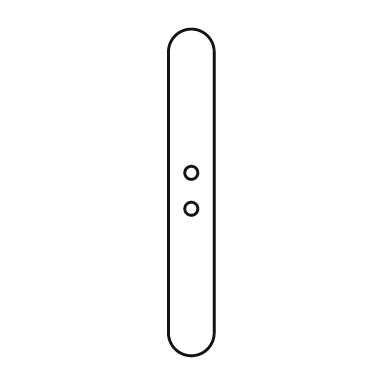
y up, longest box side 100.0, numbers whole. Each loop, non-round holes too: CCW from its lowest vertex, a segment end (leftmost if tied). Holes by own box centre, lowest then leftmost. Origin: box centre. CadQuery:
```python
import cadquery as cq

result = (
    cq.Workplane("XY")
    .moveTo(-7.0, -43.0)
    .threePointArc((0.0, -50.0), (7.0, -43.0))
    .lineTo(7.0, 43.0)
    .threePointArc((0.0, 50.0), (-7.0, 43.0))
    .close()
    .moveTo(0.0, -5.0)
    .circle(2.0)
    .moveTo(0.0, 6.0)
    .circle(2.0)
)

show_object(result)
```